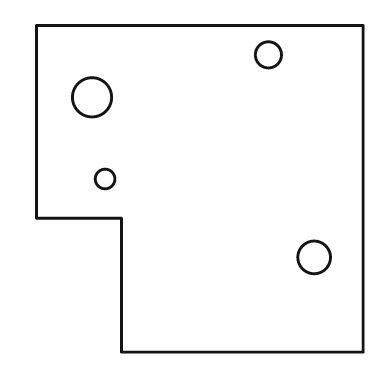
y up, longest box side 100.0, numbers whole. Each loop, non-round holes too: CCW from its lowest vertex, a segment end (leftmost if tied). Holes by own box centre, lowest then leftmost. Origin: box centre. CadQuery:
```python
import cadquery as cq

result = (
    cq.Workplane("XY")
    .moveTo(-24.0, -50.0)
    .lineTo(50.0, -50.0)
    .lineTo(50.0, 50.0)
    .lineTo(-50.0, 50.0)
    .lineTo(-50.0, -9.0)
    .lineTo(-24.0, -9.0)
    .close()
    .moveTo(35.0, -21.0)
    .circle(5.0)
    .moveTo(-29.0, 3.0)
    .circle(3.0)
    .moveTo(-33.0, 28.0)
    .circle(6.0)
    .moveTo(21.0, 41.0)
    .circle(4.0)
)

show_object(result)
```